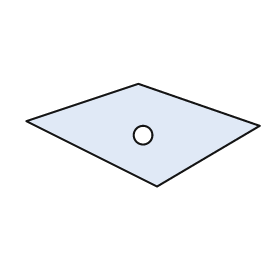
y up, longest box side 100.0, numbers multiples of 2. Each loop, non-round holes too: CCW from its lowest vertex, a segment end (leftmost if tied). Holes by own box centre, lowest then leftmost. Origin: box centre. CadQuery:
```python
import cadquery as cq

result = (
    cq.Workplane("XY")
    .moveTo(6.0, -22.0)
    .lineTo(50.0, 4.0)
    .lineTo(-2.0, 22.0)
    .lineTo(-50.0, 6.0)
    .close()
    .moveTo(0.0, 0.0)
    .circle(4.0)
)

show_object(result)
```